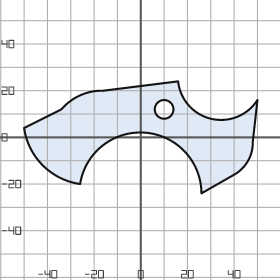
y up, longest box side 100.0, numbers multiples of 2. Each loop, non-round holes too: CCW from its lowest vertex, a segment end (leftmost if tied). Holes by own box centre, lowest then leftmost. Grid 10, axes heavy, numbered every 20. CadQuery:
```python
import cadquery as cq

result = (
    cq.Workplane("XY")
    .moveTo(26.0, -24.0)
    .lineTo(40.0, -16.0)
    .threePointArc((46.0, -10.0), (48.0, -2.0))
    .lineTo(50.0, 16.0)
    .threePointArc((30.0, 8.0), (16.0, 24.0))
    .lineTo(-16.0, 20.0)
    .threePointArc((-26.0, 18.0), (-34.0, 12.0))
    .lineTo(-50.0, 4.0)
    .threePointArc((-42.0, -12.0), (-26.0, -20.0))
    .threePointArc((2.0, 2.0), (26.0, -24.0))
    .close()
    .moveTo(10.0, 12.0)
    .circle(4.0)
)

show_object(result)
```